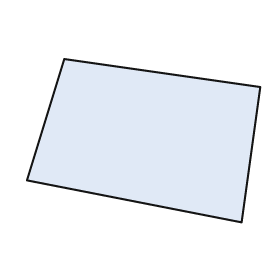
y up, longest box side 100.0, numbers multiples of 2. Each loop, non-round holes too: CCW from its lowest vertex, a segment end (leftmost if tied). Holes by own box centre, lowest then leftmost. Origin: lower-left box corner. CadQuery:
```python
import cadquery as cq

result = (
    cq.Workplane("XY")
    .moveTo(92.0, 0.0)
    .lineTo(100.0, 58.0)
    .lineTo(16.0, 70.0)
    .lineTo(0.0, 18.0)
    .close()
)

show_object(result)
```